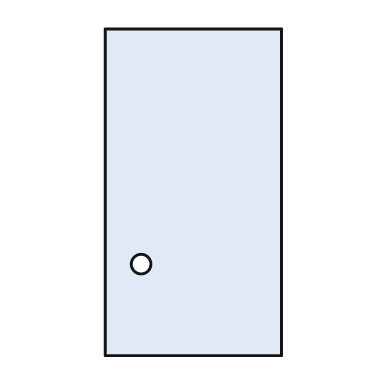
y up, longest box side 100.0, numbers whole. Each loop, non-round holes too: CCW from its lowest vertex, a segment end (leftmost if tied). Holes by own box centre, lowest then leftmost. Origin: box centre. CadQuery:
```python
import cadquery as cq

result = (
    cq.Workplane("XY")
    .moveTo(-27.0, -50.0)
    .lineTo(27.0, -50.0)
    .lineTo(27.0, 50.0)
    .lineTo(-27.0, 50.0)
    .close()
    .moveTo(-16.0, -22.0)
    .circle(3.0)
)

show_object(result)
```